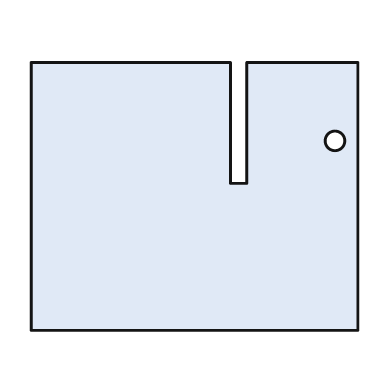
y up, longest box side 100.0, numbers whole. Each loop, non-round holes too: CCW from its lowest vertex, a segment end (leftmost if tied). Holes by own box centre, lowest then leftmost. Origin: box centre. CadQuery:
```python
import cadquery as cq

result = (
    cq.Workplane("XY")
    .moveTo(-50.0, -41.0)
    .lineTo(50.0, -41.0)
    .lineTo(50.0, 41.0)
    .lineTo(16.0, 41.0)
    .lineTo(16.0, 4.0)
    .lineTo(11.0, 4.0)
    .lineTo(11.0, 41.0)
    .lineTo(-50.0, 41.0)
    .close()
    .moveTo(43.0, 17.0)
    .circle(3.0)
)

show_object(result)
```